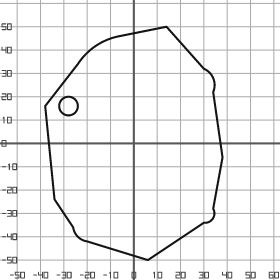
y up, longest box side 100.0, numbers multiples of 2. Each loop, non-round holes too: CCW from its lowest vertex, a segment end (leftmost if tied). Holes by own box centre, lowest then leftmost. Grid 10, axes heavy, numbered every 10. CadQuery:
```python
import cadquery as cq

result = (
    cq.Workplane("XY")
    .moveTo(6.0, -50.0)
    .lineTo(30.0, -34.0)
    .threePointArc((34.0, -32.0), (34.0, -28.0))
    .lineTo(38.0, -6.0)
    .lineTo(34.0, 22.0)
    .threePointArc((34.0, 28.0), (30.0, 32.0))
    .lineTo(14.0, 50.0)
    .lineTo(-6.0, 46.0)
    .threePointArc((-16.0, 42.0), (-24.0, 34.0))
    .lineTo(-38.0, 16.0)
    .lineTo(-34.0, -24.0)
    .lineTo(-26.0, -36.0)
    .threePointArc((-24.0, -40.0), (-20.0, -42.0))
    .close()
    .moveTo(-28.0, 16.0)
    .circle(4.0)
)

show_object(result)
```